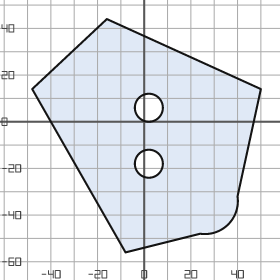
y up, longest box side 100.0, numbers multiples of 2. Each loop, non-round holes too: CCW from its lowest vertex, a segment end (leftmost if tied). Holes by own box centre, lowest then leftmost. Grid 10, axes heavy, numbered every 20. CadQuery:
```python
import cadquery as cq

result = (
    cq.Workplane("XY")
    .moveTo(-8.0, -56.0)
    .lineTo(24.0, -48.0)
    .threePointArc((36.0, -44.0), (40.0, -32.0))
    .lineTo(50.0, 14.0)
    .lineTo(-16.0, 44.0)
    .lineTo(-48.0, 14.0)
    .close()
    .moveTo(2.0, -18.0)
    .circle(6.0)
    .moveTo(2.0, 6.0)
    .circle(6.0)
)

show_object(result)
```